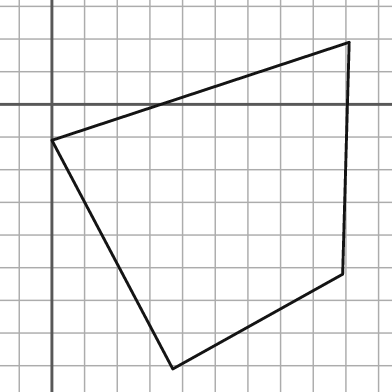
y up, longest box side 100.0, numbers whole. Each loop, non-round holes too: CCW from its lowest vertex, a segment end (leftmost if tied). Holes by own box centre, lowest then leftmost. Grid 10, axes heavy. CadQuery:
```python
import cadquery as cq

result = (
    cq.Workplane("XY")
    .moveTo(37.0, -81.0)
    .lineTo(89.0, -52.0)
    .lineTo(91.0, 19.0)
    .lineTo(0.0, -11.0)
    .close()
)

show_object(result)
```